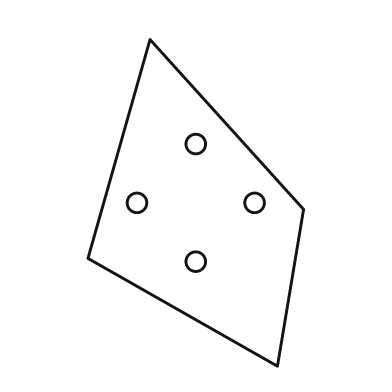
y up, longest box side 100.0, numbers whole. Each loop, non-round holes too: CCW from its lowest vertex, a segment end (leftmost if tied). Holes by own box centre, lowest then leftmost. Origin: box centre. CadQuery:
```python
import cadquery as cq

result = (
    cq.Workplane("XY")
    .moveTo(25.0, -50.0)
    .lineTo(33.0, -2.0)
    .lineTo(-14.0, 50.0)
    .lineTo(-33.0, -17.0)
    .close()
    .moveTo(0.0, -18.0)
    .circle(3.0)
    .moveTo(-18.0, 0.0)
    .circle(3.0)
    .moveTo(18.0, 0.0)
    .circle(3.0)
    .moveTo(0.0, 18.0)
    .circle(3.0)
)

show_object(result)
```